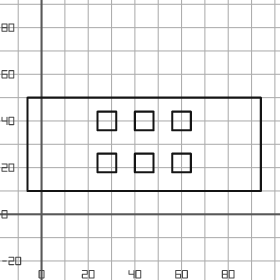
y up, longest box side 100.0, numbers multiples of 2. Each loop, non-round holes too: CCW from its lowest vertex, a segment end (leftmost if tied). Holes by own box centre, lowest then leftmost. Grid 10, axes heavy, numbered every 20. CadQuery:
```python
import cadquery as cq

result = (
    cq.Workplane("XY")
    .moveTo(-6.0, 10.0)
    .lineTo(94.0, 10.0)
    .lineTo(94.0, 50.0)
    .lineTo(-6.0, 50.0)
    .close()
    .moveTo(24.0, 18.0)
    .lineTo(32.0, 18.0)
    .lineTo(32.0, 26.0)
    .lineTo(24.0, 26.0)
    .close()
    .moveTo(40.0, 18.0)
    .lineTo(48.0, 18.0)
    .lineTo(48.0, 26.0)
    .lineTo(40.0, 26.0)
    .close()
    .moveTo(56.0, 18.0)
    .lineTo(64.0, 18.0)
    .lineTo(64.0, 26.0)
    .lineTo(56.0, 26.0)
    .close()
    .moveTo(24.0, 36.0)
    .lineTo(32.0, 36.0)
    .lineTo(32.0, 44.0)
    .lineTo(24.0, 44.0)
    .close()
    .moveTo(40.0, 36.0)
    .lineTo(48.0, 36.0)
    .lineTo(48.0, 44.0)
    .lineTo(40.0, 44.0)
    .close()
    .moveTo(56.0, 36.0)
    .lineTo(64.0, 36.0)
    .lineTo(64.0, 44.0)
    .lineTo(56.0, 44.0)
    .close()
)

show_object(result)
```